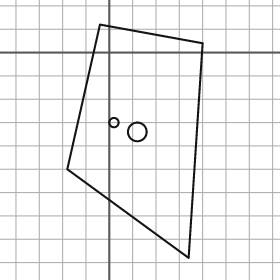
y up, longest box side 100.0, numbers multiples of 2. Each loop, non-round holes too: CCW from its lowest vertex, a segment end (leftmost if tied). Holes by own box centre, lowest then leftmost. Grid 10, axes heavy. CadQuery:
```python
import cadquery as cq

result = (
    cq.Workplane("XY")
    .moveTo(34.0, -88.0)
    .lineTo(40.0, 4.0)
    .lineTo(-4.0, 12.0)
    .lineTo(-18.0, -50.0)
    .close()
    .moveTo(12.0, -34.0)
    .circle(4.0)
    .moveTo(2.0, -30.0)
    .circle(2.0)
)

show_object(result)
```